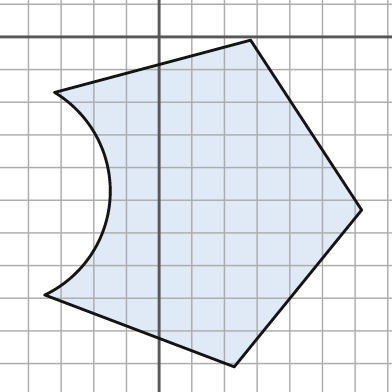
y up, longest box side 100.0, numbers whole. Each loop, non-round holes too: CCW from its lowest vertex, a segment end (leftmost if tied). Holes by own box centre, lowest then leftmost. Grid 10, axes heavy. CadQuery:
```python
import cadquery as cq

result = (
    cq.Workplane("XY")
    .moveTo(23.0, -101.0)
    .lineTo(62.0, -53.0)
    .lineTo(28.0, -1.0)
    .lineTo(-32.0, -17.0)
    .threePointArc((-15.0, -49.0), (-35.0, -79.0))
    .close()
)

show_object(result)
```